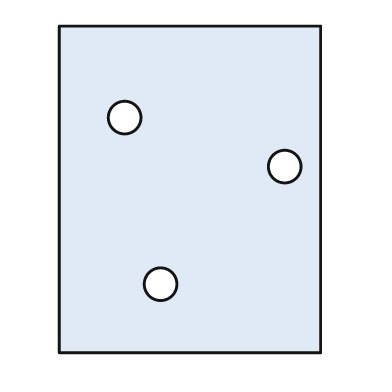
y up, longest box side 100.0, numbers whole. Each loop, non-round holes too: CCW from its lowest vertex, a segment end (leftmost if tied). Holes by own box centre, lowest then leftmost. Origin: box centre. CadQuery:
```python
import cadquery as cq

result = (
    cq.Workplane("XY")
    .moveTo(-40.0, -50.0)
    .lineTo(40.0, -50.0)
    .lineTo(40.0, 50.0)
    .lineTo(-40.0, 50.0)
    .close()
    .moveTo(-9.0, -29.0)
    .circle(5.0)
    .moveTo(29.0, 7.0)
    .circle(5.0)
    .moveTo(-20.0, 22.0)
    .circle(5.0)
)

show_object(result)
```